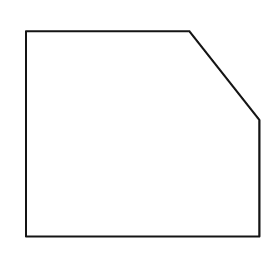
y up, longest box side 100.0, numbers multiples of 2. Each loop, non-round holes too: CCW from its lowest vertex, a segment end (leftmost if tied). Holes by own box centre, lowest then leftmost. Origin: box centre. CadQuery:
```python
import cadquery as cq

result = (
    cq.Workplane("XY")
    .moveTo(-50.0, -44.0)
    .lineTo(50.0, -44.0)
    .lineTo(50.0, 6.0)
    .lineTo(20.0, 44.0)
    .lineTo(-50.0, 44.0)
    .close()
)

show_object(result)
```